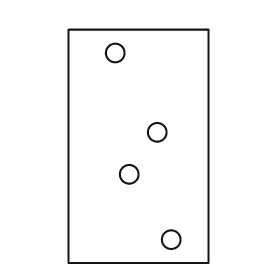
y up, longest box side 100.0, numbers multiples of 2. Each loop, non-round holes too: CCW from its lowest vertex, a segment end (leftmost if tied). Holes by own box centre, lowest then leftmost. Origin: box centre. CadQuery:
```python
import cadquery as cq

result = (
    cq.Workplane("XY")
    .moveTo(-30.0, -50.0)
    .lineTo(30.0, -50.0)
    .lineTo(30.0, 50.0)
    .lineTo(-30.0, 50.0)
    .close()
    .moveTo(14.0, -40.0)
    .circle(4.0)
    .moveTo(-4.0, -12.0)
    .circle(4.0)
    .moveTo(8.0, 6.0)
    .circle(4.0)
    .moveTo(-10.0, 40.0)
    .circle(4.0)
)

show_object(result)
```